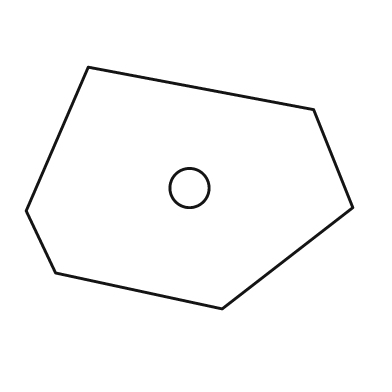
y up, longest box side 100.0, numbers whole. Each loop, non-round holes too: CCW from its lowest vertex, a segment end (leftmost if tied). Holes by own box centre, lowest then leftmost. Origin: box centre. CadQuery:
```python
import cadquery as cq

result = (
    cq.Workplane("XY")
    .moveTo(10.0, -37.0)
    .lineTo(50.0, -6.0)
    .lineTo(38.0, 24.0)
    .lineTo(-31.0, 37.0)
    .lineTo(-50.0, -7.0)
    .lineTo(-41.0, -26.0)
    .close()
    .moveTo(0.0, 0.0)
    .circle(6.0)
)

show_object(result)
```